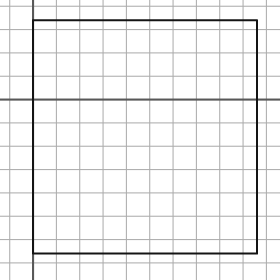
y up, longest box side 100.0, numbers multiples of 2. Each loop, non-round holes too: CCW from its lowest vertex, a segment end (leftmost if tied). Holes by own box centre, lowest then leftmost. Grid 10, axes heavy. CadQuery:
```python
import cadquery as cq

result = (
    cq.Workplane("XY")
    .moveTo(0.0, -66.0)
    .lineTo(96.0, -66.0)
    .lineTo(96.0, 34.0)
    .lineTo(0.0, 34.0)
    .close()
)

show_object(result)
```